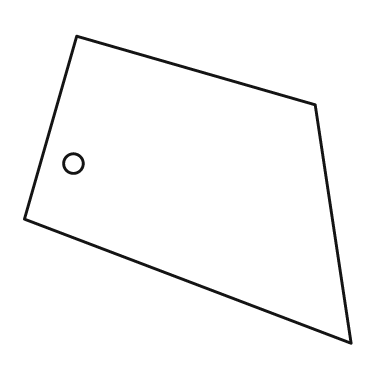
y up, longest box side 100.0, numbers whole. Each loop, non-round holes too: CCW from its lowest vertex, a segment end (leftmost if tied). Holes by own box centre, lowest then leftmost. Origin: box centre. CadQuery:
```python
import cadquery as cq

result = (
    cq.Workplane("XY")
    .moveTo(50.0, -47.0)
    .lineTo(39.0, 26.0)
    .lineTo(-34.0, 47.0)
    .lineTo(-50.0, -9.0)
    .close()
    .moveTo(-35.0, 8.0)
    .circle(3.0)
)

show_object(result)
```